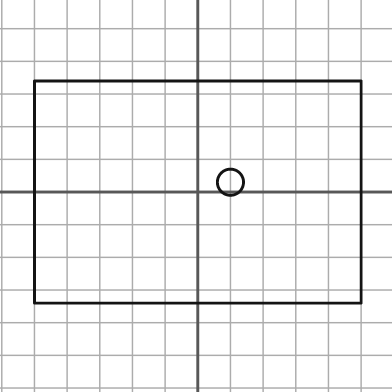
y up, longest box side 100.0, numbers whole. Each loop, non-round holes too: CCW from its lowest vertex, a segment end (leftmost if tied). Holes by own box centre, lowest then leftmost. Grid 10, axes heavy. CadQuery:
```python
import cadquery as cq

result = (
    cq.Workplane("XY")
    .moveTo(-50.0, -34.0)
    .lineTo(50.0, -34.0)
    .lineTo(50.0, 34.0)
    .lineTo(-50.0, 34.0)
    .close()
    .moveTo(10.0, 3.0)
    .circle(4.0)
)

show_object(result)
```